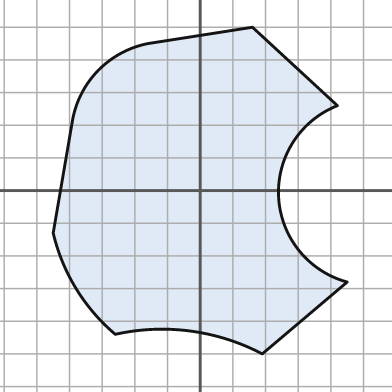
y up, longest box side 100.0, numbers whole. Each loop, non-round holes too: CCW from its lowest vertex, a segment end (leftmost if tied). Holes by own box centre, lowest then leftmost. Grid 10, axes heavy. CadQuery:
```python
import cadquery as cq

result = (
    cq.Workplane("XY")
    .moveTo(19.0, -50.0)
    .lineTo(45.0, -28.0)
    .threePointArc((24.0, -2.0), (42.0, 26.0))
    .lineTo(16.0, 50.0)
    .lineTo(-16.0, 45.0)
    .threePointArc((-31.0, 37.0), (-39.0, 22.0))
    .lineTo(-45.0, -13.0)
    .threePointArc((-38.0, -30.0), (-26.0, -44.0))
    .threePointArc((-3.0, -43.0), (19.0, -50.0))
    .close()
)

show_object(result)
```